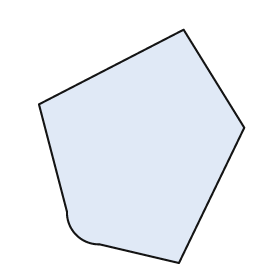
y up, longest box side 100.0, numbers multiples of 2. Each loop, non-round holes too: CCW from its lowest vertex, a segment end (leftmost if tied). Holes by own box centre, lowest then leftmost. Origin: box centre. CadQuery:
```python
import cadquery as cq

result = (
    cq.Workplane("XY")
    .moveTo(16.0, -50.0)
    .lineTo(44.0, 8.0)
    .lineTo(18.0, 50.0)
    .lineTo(-44.0, 18.0)
    .lineTo(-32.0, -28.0)
    .threePointArc((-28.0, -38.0), (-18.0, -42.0))
    .close()
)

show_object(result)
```